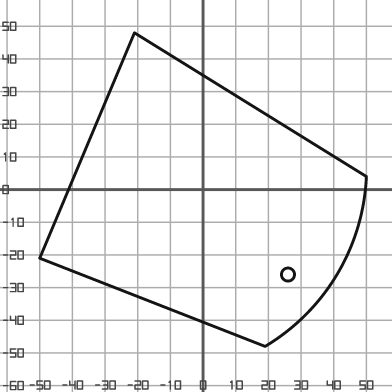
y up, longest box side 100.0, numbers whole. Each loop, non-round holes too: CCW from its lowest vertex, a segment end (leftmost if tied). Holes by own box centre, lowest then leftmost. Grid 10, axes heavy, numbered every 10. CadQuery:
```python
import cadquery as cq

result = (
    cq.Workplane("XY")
    .moveTo(19.0, -48.0)
    .threePointArc((41.0, -26.0), (50.0, 4.0))
    .lineTo(-21.0, 48.0)
    .lineTo(-50.0, -21.0)
    .close()
    .moveTo(26.0, -26.0)
    .circle(2.0)
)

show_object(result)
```